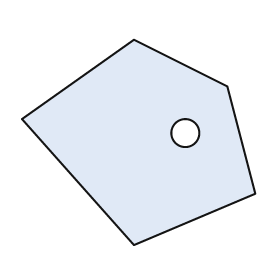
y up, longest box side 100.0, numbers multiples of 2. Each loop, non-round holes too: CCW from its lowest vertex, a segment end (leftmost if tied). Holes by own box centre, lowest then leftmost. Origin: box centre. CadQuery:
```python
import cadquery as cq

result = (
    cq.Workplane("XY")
    .moveTo(-2.0, -44.0)
    .lineTo(50.0, -22.0)
    .lineTo(38.0, 24.0)
    .lineTo(-2.0, 44.0)
    .lineTo(-50.0, 10.0)
    .close()
    .moveTo(20.0, 4.0)
    .circle(6.0)
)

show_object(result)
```